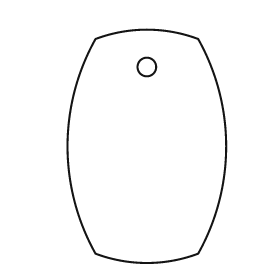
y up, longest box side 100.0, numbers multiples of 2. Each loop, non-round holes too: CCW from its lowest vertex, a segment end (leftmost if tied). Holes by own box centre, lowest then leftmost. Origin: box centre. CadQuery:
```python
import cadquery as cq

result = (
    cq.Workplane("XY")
    .moveTo(-22.0, -46.0)
    .threePointArc((0.0, -50.0), (22.0, -46.0))
    .threePointArc((34.0, 0.0), (22.0, 46.0))
    .threePointArc((0.0, 50.0), (-22.0, 46.0))
    .threePointArc((-34.0, 0.0), (-22.0, -46.0))
    .close()
    .moveTo(0.0, 34.0)
    .circle(4.0)
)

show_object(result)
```